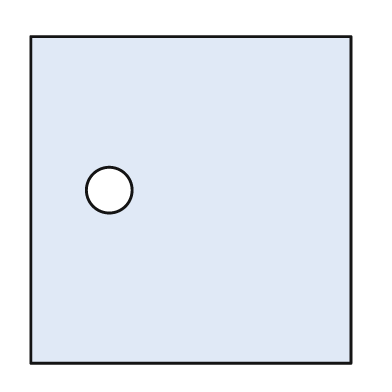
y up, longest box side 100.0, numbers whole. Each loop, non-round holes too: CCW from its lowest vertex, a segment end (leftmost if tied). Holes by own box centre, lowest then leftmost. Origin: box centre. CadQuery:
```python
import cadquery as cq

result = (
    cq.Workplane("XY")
    .moveTo(-49.0, -50.0)
    .lineTo(49.0, -50.0)
    .lineTo(49.0, 50.0)
    .lineTo(-49.0, 50.0)
    .close()
    .moveTo(-25.0, 3.0)
    .circle(7.0)
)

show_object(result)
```